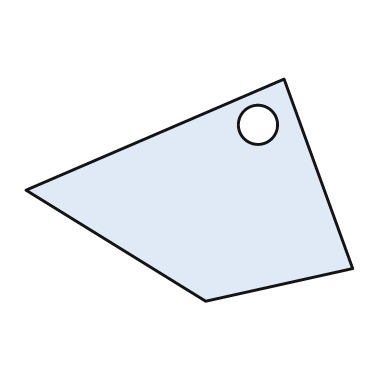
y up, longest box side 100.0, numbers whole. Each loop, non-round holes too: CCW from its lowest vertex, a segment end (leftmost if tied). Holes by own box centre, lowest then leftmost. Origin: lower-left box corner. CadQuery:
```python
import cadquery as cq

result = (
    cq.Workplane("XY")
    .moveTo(55.0, 0.0)
    .lineTo(100.0, 10.0)
    .lineTo(79.0, 68.0)
    .lineTo(0.0, 34.0)
    .close()
    .moveTo(71.0, 54.0)
    .circle(6.0)
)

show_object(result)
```